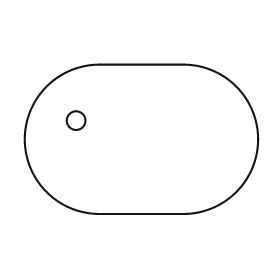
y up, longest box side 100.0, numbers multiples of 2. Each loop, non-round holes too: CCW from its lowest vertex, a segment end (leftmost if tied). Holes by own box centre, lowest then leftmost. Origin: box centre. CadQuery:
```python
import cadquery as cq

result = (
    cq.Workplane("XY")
    .moveTo(-18.0, -32.0)
    .lineTo(18.0, -32.0)
    .threePointArc((50.0, 0.0), (18.0, 32.0))
    .lineTo(-18.0, 32.0)
    .threePointArc((-50.0, 0.0), (-18.0, -32.0))
    .close()
    .moveTo(-28.0, 8.0)
    .circle(4.0)
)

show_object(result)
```